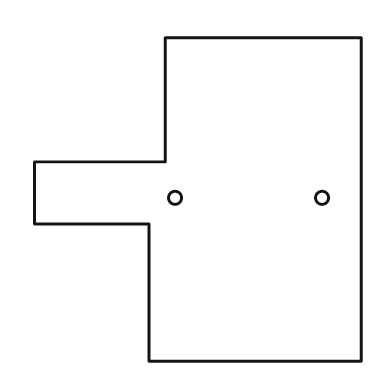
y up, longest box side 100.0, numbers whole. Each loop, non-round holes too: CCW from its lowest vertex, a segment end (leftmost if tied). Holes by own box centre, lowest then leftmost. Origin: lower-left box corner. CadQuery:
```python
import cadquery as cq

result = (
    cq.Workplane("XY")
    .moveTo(35.0, 0.0)
    .lineTo(100.0, 0.0)
    .lineTo(100.0, 99.0)
    .lineTo(40.0, 99.0)
    .lineTo(40.0, 61.0)
    .lineTo(0.0, 61.0)
    .lineTo(0.0, 42.0)
    .lineTo(35.0, 42.0)
    .close()
    .moveTo(43.0, 50.0)
    .circle(2.0)
    .moveTo(88.0, 50.0)
    .circle(2.0)
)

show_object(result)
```